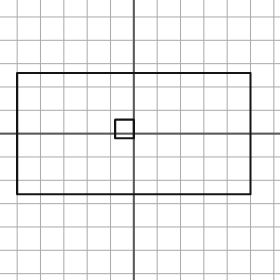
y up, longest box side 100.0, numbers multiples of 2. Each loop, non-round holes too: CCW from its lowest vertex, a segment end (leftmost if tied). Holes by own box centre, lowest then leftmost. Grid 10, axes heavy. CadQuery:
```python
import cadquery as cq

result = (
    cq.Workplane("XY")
    .moveTo(-50.0, -26.0)
    .lineTo(50.0, -26.0)
    .lineTo(50.0, 26.0)
    .lineTo(-50.0, 26.0)
    .close()
    .moveTo(-8.0, -2.0)
    .lineTo(0.0, -2.0)
    .lineTo(0.0, 6.0)
    .lineTo(-8.0, 6.0)
    .close()
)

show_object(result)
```